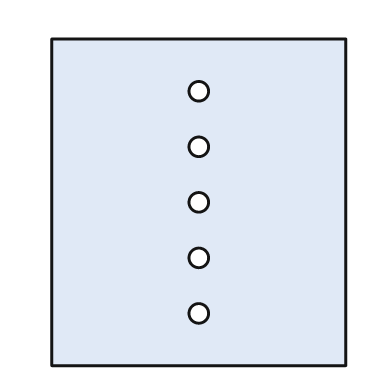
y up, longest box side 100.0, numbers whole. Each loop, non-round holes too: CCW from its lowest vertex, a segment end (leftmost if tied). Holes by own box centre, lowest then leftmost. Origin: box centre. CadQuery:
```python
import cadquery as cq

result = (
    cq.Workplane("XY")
    .moveTo(-45.0, -50.0)
    .lineTo(45.0, -50.0)
    .lineTo(45.0, 50.0)
    .lineTo(-45.0, 50.0)
    .close()
    .moveTo(0.0, -34.0)
    .circle(3.0)
    .moveTo(0.0, -17.0)
    .circle(3.0)
    .moveTo(0.0, 0.0)
    .circle(3.0)
    .moveTo(0.0, 17.0)
    .circle(3.0)
    .moveTo(0.0, 34.0)
    .circle(3.0)
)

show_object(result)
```